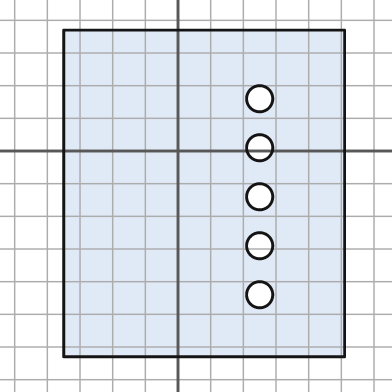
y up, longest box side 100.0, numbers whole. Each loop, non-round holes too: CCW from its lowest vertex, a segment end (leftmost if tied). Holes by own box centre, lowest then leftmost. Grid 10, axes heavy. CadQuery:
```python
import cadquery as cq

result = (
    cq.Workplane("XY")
    .moveTo(-35.0, -63.0)
    .lineTo(51.0, -63.0)
    .lineTo(51.0, 37.0)
    .lineTo(-35.0, 37.0)
    .close()
    .moveTo(25.0, -44.0)
    .circle(4.0)
    .moveTo(25.0, -29.0)
    .circle(4.0)
    .moveTo(25.0, -14.0)
    .circle(4.0)
    .moveTo(25.0, 1.0)
    .circle(4.0)
    .moveTo(25.0, 16.0)
    .circle(4.0)
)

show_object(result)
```